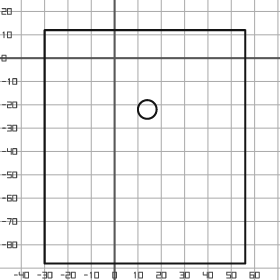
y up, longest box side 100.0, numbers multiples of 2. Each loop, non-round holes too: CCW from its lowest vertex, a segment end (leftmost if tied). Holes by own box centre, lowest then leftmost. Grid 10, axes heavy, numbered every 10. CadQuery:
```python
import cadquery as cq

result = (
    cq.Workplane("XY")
    .moveTo(-30.0, -88.0)
    .lineTo(56.0, -88.0)
    .lineTo(56.0, 12.0)
    .lineTo(-30.0, 12.0)
    .close()
    .moveTo(14.0, -22.0)
    .circle(4.0)
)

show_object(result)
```